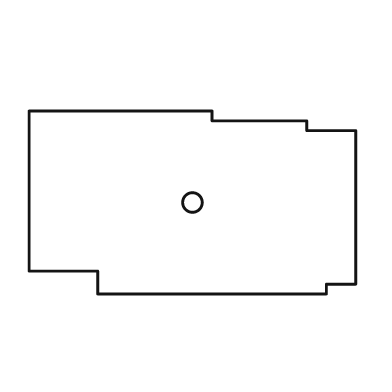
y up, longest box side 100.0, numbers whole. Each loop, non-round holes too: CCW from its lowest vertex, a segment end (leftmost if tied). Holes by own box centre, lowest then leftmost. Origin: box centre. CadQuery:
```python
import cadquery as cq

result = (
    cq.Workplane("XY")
    .moveTo(-29.0, -28.0)
    .lineTo(41.0, -28.0)
    .lineTo(41.0, -25.0)
    .lineTo(50.0, -25.0)
    .lineTo(50.0, 22.0)
    .lineTo(35.0, 22.0)
    .lineTo(35.0, 25.0)
    .lineTo(6.0, 25.0)
    .lineTo(6.0, 28.0)
    .lineTo(-50.0, 28.0)
    .lineTo(-50.0, -21.0)
    .lineTo(-29.0, -21.0)
    .close()
    .moveTo(0.0, 0.0)
    .circle(3.0)
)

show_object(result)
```